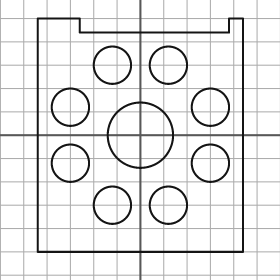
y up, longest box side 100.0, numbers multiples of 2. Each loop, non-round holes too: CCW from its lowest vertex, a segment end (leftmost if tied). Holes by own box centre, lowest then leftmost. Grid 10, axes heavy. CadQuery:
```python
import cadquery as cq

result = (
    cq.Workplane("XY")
    .moveTo(-44.0, -50.0)
    .lineTo(44.0, -50.0)
    .lineTo(44.0, 50.0)
    .lineTo(38.0, 50.0)
    .lineTo(38.0, 44.0)
    .lineTo(-26.0, 44.0)
    .lineTo(-26.0, 50.0)
    .lineTo(-44.0, 50.0)
    .close()
    .moveTo(-12.0, -30.0)
    .circle(8.0)
    .moveTo(12.0, -30.0)
    .circle(8.0)
    .moveTo(-30.0, -12.0)
    .circle(8.0)
    .moveTo(30.0, -12.0)
    .circle(8.0)
    .moveTo(0.0, 0.0)
    .circle(14.0)
    .moveTo(-30.0, 12.0)
    .circle(8.0)
    .moveTo(30.0, 12.0)
    .circle(8.0)
    .moveTo(-12.0, 30.0)
    .circle(8.0)
    .moveTo(12.0, 30.0)
    .circle(8.0)
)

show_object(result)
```